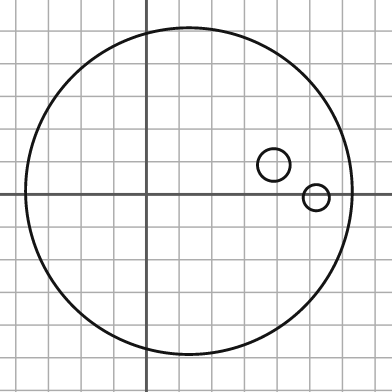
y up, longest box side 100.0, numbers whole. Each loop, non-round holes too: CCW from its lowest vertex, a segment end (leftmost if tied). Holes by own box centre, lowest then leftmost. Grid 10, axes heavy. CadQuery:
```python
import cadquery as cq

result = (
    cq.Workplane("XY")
    .moveTo(13.0, 1.0)
    .circle(50.0)
    .moveTo(52.0, -1.0)
    .circle(4.0)
    .moveTo(39.0, 9.0)
    .circle(5.0)
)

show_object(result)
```